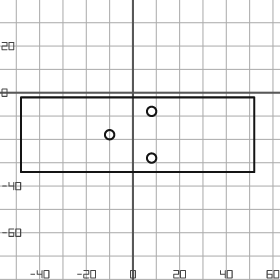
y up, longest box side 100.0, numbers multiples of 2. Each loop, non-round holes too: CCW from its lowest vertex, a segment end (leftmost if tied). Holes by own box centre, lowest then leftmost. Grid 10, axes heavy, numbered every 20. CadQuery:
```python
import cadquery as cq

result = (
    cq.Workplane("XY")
    .moveTo(-48.0, -34.0)
    .lineTo(52.0, -34.0)
    .lineTo(52.0, -2.0)
    .lineTo(-48.0, -2.0)
    .close()
    .moveTo(8.0, -28.0)
    .circle(2.0)
    .moveTo(-10.0, -18.0)
    .circle(2.0)
    .moveTo(8.0, -8.0)
    .circle(2.0)
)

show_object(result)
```